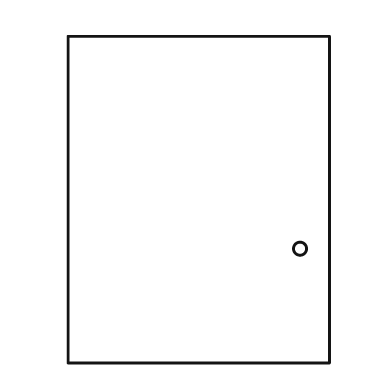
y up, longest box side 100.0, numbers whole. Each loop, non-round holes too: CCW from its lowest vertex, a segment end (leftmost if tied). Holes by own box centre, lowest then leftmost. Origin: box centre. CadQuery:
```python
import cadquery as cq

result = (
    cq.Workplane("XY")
    .moveTo(-40.0, -50.0)
    .lineTo(40.0, -50.0)
    .lineTo(40.0, 50.0)
    .lineTo(-40.0, 50.0)
    .close()
    .moveTo(31.0, -15.0)
    .circle(2.0)
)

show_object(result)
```